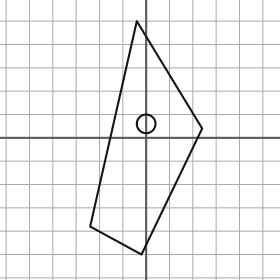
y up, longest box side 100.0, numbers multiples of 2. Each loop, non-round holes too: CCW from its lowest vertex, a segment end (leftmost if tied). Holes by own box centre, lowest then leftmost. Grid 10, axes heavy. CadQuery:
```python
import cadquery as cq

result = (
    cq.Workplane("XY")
    .moveTo(-2.0, -50.0)
    .lineTo(24.0, 4.0)
    .lineTo(-4.0, 50.0)
    .lineTo(-24.0, -38.0)
    .close()
    .moveTo(0.0, 6.0)
    .circle(4.0)
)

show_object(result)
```